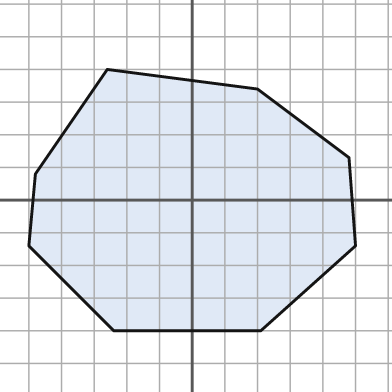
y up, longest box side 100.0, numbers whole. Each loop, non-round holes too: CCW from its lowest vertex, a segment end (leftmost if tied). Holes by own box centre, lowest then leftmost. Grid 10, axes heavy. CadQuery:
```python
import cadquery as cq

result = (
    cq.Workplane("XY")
    .moveTo(-24.0, -40.0)
    .lineTo(21.0, -40.0)
    .lineTo(50.0, -14.0)
    .lineTo(48.0, 13.0)
    .lineTo(20.0, 34.0)
    .lineTo(-26.0, 40.0)
    .lineTo(-48.0, 8.0)
    .lineTo(-50.0, -14.0)
    .close()
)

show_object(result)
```